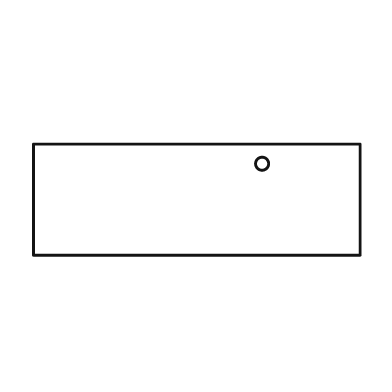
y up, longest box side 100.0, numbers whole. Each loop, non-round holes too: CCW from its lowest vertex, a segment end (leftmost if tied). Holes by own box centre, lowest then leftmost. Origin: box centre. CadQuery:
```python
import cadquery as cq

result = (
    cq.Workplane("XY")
    .moveTo(-50.0, -17.0)
    .lineTo(50.0, -17.0)
    .lineTo(50.0, 17.0)
    .lineTo(-50.0, 17.0)
    .close()
    .moveTo(20.0, 11.0)
    .circle(2.0)
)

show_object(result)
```